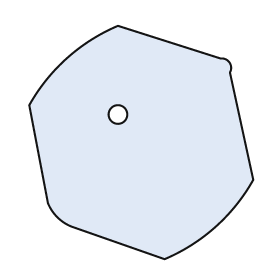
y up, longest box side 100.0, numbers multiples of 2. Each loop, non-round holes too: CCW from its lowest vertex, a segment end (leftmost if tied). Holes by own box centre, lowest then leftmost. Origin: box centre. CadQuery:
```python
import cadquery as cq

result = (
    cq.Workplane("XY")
    .moveTo(10.0, -50.0)
    .threePointArc((32.0, -36.0), (48.0, -16.0))
    .lineTo(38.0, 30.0)
    .threePointArc((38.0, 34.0), (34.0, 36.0))
    .lineTo(-10.0, 50.0)
    .threePointArc((-32.0, 36.0), (-48.0, 16.0))
    .lineTo(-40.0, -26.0)
    .threePointArc((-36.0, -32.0), (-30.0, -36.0))
    .close()
    .moveTo(-10.0, 12.0)
    .circle(4.0)
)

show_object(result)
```